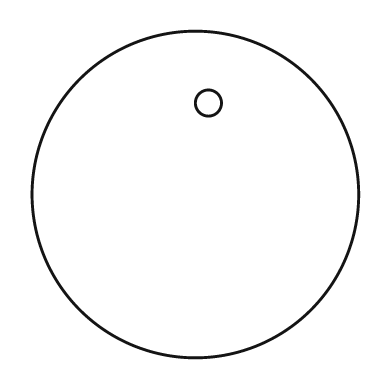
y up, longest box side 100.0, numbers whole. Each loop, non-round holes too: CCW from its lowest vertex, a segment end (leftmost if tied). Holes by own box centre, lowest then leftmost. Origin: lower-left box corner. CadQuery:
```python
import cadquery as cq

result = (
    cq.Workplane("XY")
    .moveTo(50.0, 50.0)
    .circle(50.0)
    .moveTo(54.0, 78.0)
    .circle(4.0)
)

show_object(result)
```